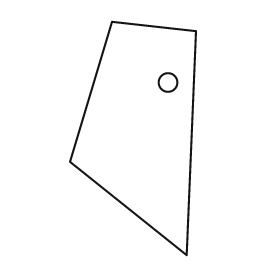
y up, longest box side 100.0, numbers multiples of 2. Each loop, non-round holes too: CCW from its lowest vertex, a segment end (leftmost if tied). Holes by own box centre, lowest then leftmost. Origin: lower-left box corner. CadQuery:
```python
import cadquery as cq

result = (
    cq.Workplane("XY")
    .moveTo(50.0, 0.0)
    .lineTo(54.0, 96.0)
    .lineTo(18.0, 100.0)
    .lineTo(0.0, 40.0)
    .close()
    .moveTo(42.0, 74.0)
    .circle(4.0)
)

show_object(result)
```